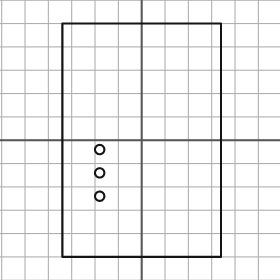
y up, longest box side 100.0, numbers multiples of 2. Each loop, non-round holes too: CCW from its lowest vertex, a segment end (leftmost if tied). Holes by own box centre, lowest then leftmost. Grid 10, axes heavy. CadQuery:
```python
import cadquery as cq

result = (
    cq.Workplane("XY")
    .moveTo(-34.0, -50.0)
    .lineTo(34.0, -50.0)
    .lineTo(34.0, 50.0)
    .lineTo(-34.0, 50.0)
    .close()
    .moveTo(-18.0, -24.0)
    .circle(2.0)
    .moveTo(-18.0, -14.0)
    .circle(2.0)
    .moveTo(-18.0, -4.0)
    .circle(2.0)
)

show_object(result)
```